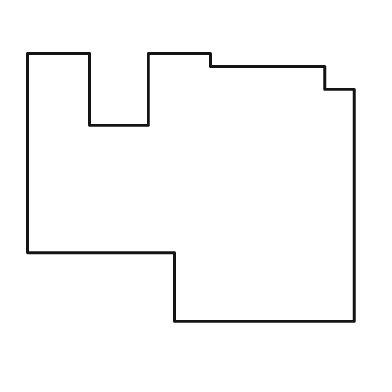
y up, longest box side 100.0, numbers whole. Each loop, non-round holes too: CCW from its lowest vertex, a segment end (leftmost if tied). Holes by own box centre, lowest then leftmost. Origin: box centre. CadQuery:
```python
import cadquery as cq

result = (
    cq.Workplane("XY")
    .moveTo(-5.0, -41.0)
    .lineTo(50.0, -41.0)
    .lineTo(50.0, 30.0)
    .lineTo(41.0, 30.0)
    .lineTo(41.0, 37.0)
    .lineTo(6.0, 37.0)
    .lineTo(6.0, 41.0)
    .lineTo(-13.0, 41.0)
    .lineTo(-13.0, 19.0)
    .lineTo(-31.0, 19.0)
    .lineTo(-31.0, 41.0)
    .lineTo(-50.0, 41.0)
    .lineTo(-50.0, -20.0)
    .lineTo(-5.0, -20.0)
    .close()
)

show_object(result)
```